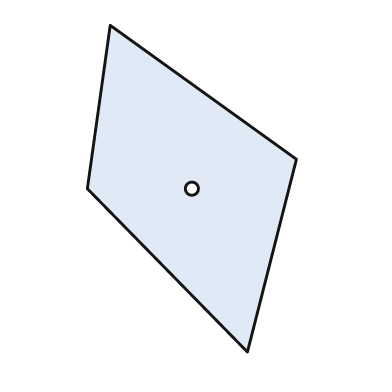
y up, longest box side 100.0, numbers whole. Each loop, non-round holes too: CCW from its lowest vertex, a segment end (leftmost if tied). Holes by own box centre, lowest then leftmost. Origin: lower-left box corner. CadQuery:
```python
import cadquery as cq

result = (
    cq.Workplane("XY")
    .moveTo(49.0, 0.0)
    .lineTo(64.0, 59.0)
    .lineTo(7.0, 100.0)
    .lineTo(0.0, 50.0)
    .close()
    .moveTo(32.0, 50.0)
    .circle(2.0)
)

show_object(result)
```